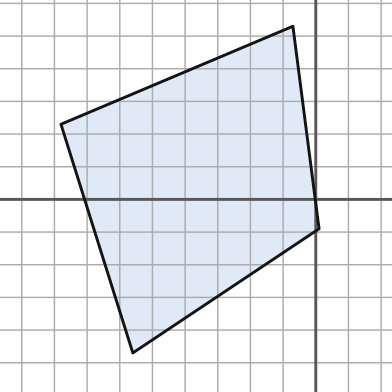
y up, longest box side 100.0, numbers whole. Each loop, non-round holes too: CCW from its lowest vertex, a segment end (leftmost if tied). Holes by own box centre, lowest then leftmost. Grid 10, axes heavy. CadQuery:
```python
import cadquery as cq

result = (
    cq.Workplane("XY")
    .moveTo(-56.0, -47.0)
    .lineTo(1.0, -9.0)
    .lineTo(-7.0, 53.0)
    .lineTo(-78.0, 23.0)
    .close()
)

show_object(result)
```